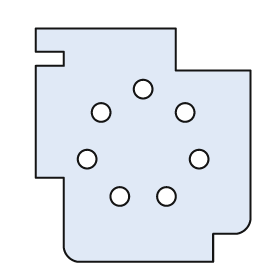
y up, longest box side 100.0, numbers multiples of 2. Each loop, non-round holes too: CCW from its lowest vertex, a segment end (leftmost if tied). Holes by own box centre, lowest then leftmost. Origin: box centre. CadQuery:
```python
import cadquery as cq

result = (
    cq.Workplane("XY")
    .moveTo(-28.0, -50.0)
    .lineTo(30.0, -50.0)
    .lineTo(30.0, -38.0)
    .lineTo(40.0, -38.0)
    .threePointArc((44.0, -36.0), (46.0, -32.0))
    .lineTo(46.0, 32.0)
    .lineTo(14.0, 32.0)
    .lineTo(14.0, 50.0)
    .lineTo(-46.0, 50.0)
    .lineTo(-46.0, 40.0)
    .lineTo(-34.0, 40.0)
    .lineTo(-34.0, 34.0)
    .lineTo(-46.0, 34.0)
    .lineTo(-46.0, -14.0)
    .lineTo(-34.0, -14.0)
    .lineTo(-34.0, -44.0)
    .threePointArc((-32.0, -48.0), (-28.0, -50.0))
    .close()
    .moveTo(-10.0, -22.0)
    .circle(4.0)
    .moveTo(10.0, -22.0)
    .circle(4.0)
    .moveTo(-24.0, -6.0)
    .circle(4.0)
    .moveTo(24.0, -6.0)
    .circle(4.0)
    .moveTo(-18.0, 14.0)
    .circle(4.0)
    .moveTo(18.0, 14.0)
    .circle(4.0)
    .moveTo(0.0, 24.0)
    .circle(4.0)
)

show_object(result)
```